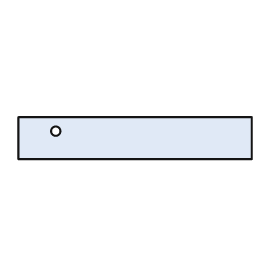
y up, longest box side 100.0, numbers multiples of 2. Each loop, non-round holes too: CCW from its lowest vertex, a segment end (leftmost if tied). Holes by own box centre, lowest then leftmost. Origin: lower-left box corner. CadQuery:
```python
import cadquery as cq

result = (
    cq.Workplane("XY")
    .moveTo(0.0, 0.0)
    .lineTo(100.0, 0.0)
    .lineTo(100.0, 18.0)
    .lineTo(0.0, 18.0)
    .close()
    .moveTo(16.0, 12.0)
    .circle(2.0)
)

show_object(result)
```